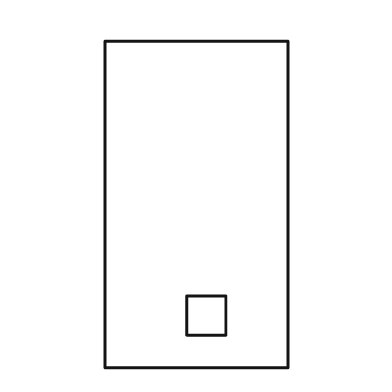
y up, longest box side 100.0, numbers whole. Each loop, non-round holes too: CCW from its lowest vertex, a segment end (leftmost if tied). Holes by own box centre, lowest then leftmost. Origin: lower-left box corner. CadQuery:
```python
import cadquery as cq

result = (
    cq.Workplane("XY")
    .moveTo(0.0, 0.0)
    .lineTo(56.0, 0.0)
    .lineTo(56.0, 100.0)
    .lineTo(0.0, 100.0)
    .close()
    .moveTo(25.0, 10.0)
    .lineTo(37.0, 10.0)
    .lineTo(37.0, 22.0)
    .lineTo(25.0, 22.0)
    .close()
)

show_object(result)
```